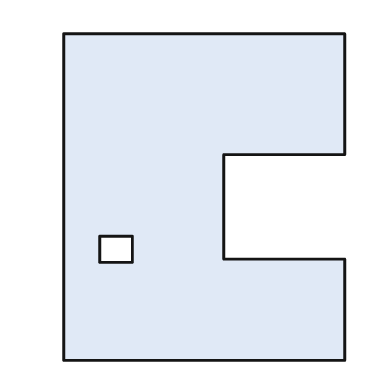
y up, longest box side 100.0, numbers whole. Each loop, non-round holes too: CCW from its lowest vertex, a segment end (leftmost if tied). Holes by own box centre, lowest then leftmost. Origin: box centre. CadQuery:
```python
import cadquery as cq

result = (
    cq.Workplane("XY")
    .moveTo(-43.0, -50.0)
    .lineTo(43.0, -50.0)
    .lineTo(43.0, -19.0)
    .lineTo(6.0, -19.0)
    .lineTo(6.0, 13.0)
    .lineTo(43.0, 13.0)
    .lineTo(43.0, 50.0)
    .lineTo(-43.0, 50.0)
    .close()
    .moveTo(-32.0, -20.0)
    .lineTo(-22.0, -20.0)
    .lineTo(-22.0, -12.0)
    .lineTo(-32.0, -12.0)
    .close()
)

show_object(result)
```